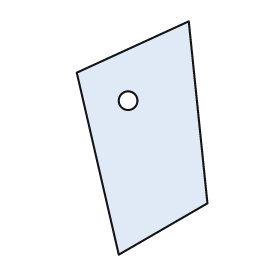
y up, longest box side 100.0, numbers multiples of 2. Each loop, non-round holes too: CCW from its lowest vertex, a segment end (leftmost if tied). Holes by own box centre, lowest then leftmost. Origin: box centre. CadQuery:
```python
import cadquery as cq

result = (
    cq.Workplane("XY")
    .moveTo(-10.0, -50.0)
    .lineTo(28.0, -28.0)
    .lineTo(20.0, 50.0)
    .lineTo(-28.0, 28.0)
    .close()
    .moveTo(-6.0, 16.0)
    .circle(4.0)
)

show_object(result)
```